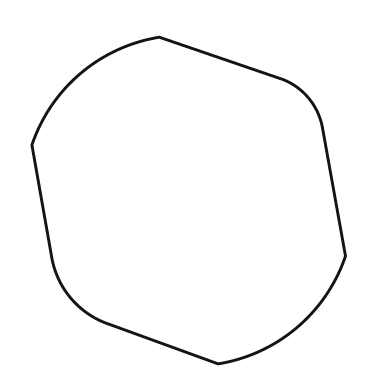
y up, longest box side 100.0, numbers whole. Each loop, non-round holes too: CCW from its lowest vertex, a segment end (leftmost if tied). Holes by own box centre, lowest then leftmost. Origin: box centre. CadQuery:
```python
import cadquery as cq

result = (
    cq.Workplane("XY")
    .moveTo(9.0, -50.0)
    .threePointArc((33.0, -39.0), (48.0, -17.0))
    .lineTo(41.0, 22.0)
    .threePointArc((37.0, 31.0), (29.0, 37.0))
    .lineTo(-9.0, 50.0)
    .threePointArc((-33.0, 39.0), (-48.0, 17.0))
    .lineTo(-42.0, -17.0)
    .threePointArc((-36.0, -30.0), (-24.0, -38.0))
    .close()
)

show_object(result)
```